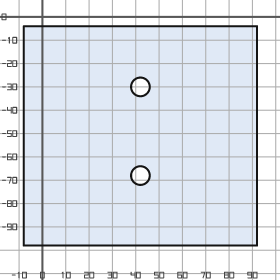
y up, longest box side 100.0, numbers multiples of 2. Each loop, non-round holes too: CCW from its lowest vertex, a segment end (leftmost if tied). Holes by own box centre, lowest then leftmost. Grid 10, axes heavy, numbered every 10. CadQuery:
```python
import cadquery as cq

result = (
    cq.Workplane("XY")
    .moveTo(-8.0, -98.0)
    .lineTo(92.0, -98.0)
    .lineTo(92.0, -4.0)
    .lineTo(-8.0, -4.0)
    .close()
    .moveTo(42.0, -68.0)
    .circle(4.0)
    .moveTo(42.0, -30.0)
    .circle(4.0)
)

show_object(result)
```